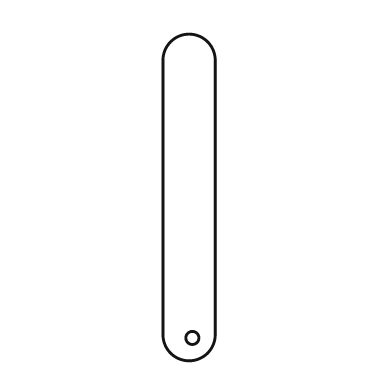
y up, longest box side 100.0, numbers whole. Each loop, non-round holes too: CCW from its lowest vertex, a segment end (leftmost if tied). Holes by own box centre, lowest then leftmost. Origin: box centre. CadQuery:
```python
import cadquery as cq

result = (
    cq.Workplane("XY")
    .moveTo(-8.0, -42.0)
    .threePointArc((0.0, -50.0), (8.0, -42.0))
    .lineTo(8.0, 42.0)
    .threePointArc((0.0, 50.0), (-8.0, 42.0))
    .close()
    .moveTo(1.0, -43.0)
    .circle(2.0)
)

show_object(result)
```